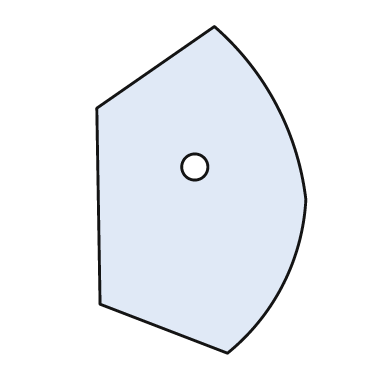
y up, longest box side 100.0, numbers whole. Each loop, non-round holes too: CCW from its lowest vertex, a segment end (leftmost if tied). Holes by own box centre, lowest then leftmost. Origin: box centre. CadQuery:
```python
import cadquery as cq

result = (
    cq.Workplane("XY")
    .moveTo(8.0, -50.0)
    .threePointArc((25.0, -29.0), (32.0, -3.0))
    .threePointArc((23.0, 26.0), (4.0, 50.0))
    .lineTo(-32.0, 25.0)
    .lineTo(-31.0, -35.0)
    .close()
    .moveTo(-2.0, 7.0)
    .circle(4.0)
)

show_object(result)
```